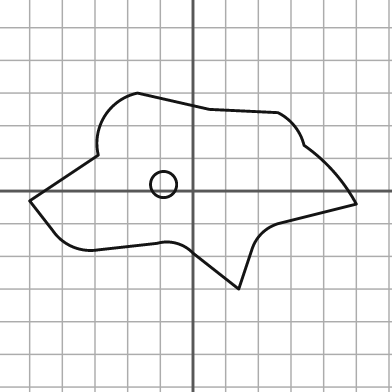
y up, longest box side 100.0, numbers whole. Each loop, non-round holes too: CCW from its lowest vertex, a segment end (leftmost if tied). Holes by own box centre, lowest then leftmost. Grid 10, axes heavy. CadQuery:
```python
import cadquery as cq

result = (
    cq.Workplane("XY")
    .moveTo(14.0, -30.0)
    .lineTo(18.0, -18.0)
    .threePointArc((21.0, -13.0), (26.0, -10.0))
    .lineTo(50.0, -4.0)
    .threePointArc((43.0, 6.0), (34.0, 14.0))
    .threePointArc((31.0, 20.0), (26.0, 24.0))
    .lineTo(5.0, 25.0)
    .lineTo(-17.0, 30.0)
    .threePointArc((-27.0, 23.0), (-29.0, 11.0))
    .lineTo(-50.0, -3.0)
    .lineTo(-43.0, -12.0)
    .threePointArc((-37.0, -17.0), (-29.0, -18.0))
    .lineTo(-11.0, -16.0)
    .threePointArc((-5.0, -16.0), (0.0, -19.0))
    .close()
    .moveTo(-9.0, 2.0)
    .circle(4.0)
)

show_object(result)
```